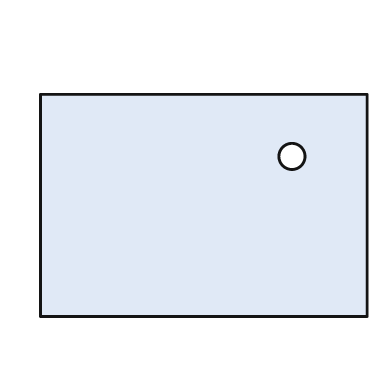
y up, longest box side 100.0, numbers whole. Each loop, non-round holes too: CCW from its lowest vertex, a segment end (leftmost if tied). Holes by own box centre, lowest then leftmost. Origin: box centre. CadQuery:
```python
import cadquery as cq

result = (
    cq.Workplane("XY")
    .moveTo(-50.0, -34.0)
    .lineTo(50.0, -34.0)
    .lineTo(50.0, 34.0)
    .lineTo(-50.0, 34.0)
    .close()
    .moveTo(27.0, 15.0)
    .circle(4.0)
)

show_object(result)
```